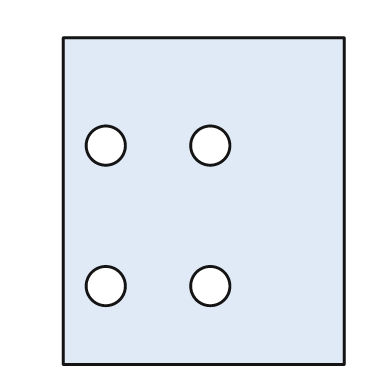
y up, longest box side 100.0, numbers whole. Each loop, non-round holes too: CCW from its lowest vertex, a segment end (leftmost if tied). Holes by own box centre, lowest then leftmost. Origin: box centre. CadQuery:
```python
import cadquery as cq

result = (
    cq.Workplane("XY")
    .moveTo(-43.0, -50.0)
    .lineTo(43.0, -50.0)
    .lineTo(43.0, 50.0)
    .lineTo(-43.0, 50.0)
    .close()
    .moveTo(-30.0, -26.0)
    .circle(6.0)
    .moveTo(2.0, -26.0)
    .circle(6.0)
    .moveTo(-30.0, 17.0)
    .circle(6.0)
    .moveTo(2.0, 17.0)
    .circle(6.0)
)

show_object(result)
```